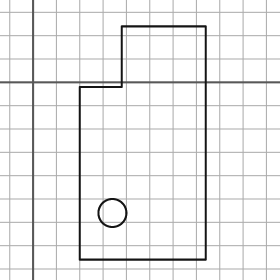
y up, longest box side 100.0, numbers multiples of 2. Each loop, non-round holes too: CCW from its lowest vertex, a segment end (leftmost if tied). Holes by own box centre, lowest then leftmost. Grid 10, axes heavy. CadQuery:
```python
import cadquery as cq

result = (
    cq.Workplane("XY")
    .moveTo(20.0, -76.0)
    .lineTo(74.0, -76.0)
    .lineTo(74.0, 24.0)
    .lineTo(38.0, 24.0)
    .lineTo(38.0, -2.0)
    .lineTo(20.0, -2.0)
    .close()
    .moveTo(34.0, -56.0)
    .circle(6.0)
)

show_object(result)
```